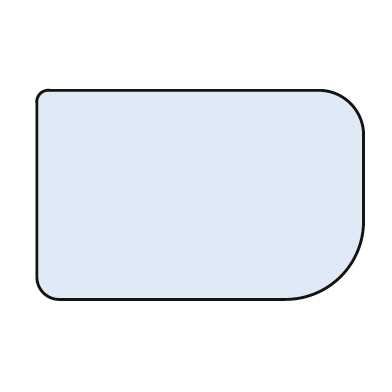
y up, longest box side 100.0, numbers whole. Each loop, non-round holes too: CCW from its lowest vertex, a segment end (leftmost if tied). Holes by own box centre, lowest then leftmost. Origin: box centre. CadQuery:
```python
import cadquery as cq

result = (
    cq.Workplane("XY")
    .moveTo(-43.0, -32.0)
    .lineTo(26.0, -32.0)
    .threePointArc((43.0, -25.0), (50.0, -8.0))
    .lineTo(50.0, 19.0)
    .threePointArc((46.0, 28.0), (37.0, 32.0))
    .lineTo(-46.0, 32.0)
    .threePointArc((-49.0, 31.0), (-50.0, 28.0))
    .lineTo(-50.0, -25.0)
    .threePointArc((-48.0, -30.0), (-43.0, -32.0))
    .close()
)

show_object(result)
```